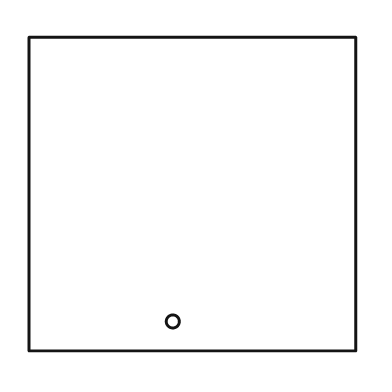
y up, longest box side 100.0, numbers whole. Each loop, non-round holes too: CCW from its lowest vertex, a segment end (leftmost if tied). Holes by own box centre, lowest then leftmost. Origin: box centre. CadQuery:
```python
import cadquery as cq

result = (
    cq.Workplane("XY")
    .moveTo(-50.0, -48.0)
    .lineTo(50.0, -48.0)
    .lineTo(50.0, 48.0)
    .lineTo(-50.0, 48.0)
    .close()
    .moveTo(-6.0, -39.0)
    .circle(2.0)
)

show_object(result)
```